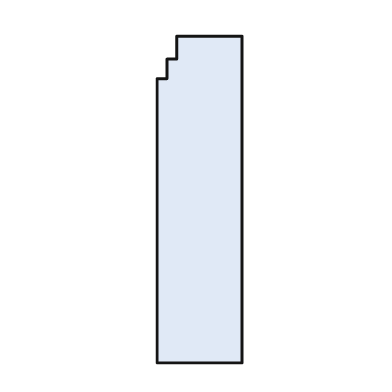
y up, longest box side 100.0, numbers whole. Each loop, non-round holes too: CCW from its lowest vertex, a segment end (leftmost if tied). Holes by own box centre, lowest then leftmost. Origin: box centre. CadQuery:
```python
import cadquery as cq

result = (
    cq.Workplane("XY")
    .moveTo(-13.0, -50.0)
    .lineTo(13.0, -50.0)
    .lineTo(13.0, 50.0)
    .lineTo(-7.0, 50.0)
    .lineTo(-7.0, 43.0)
    .lineTo(-10.0, 43.0)
    .lineTo(-10.0, 37.0)
    .lineTo(-13.0, 37.0)
    .close()
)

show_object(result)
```